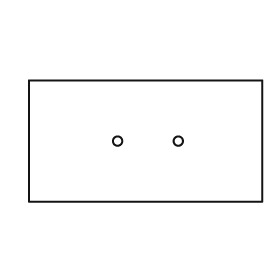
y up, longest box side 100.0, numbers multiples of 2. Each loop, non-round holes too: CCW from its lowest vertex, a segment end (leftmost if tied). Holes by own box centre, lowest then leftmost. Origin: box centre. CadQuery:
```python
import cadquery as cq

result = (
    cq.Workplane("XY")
    .moveTo(-50.0, -26.0)
    .lineTo(50.0, -26.0)
    .lineTo(50.0, 26.0)
    .lineTo(-50.0, 26.0)
    .close()
    .moveTo(-12.0, 0.0)
    .circle(2.0)
    .moveTo(14.0, 0.0)
    .circle(2.0)
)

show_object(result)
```